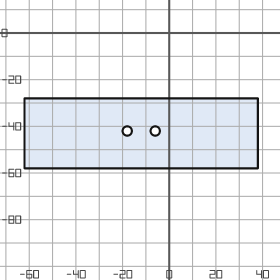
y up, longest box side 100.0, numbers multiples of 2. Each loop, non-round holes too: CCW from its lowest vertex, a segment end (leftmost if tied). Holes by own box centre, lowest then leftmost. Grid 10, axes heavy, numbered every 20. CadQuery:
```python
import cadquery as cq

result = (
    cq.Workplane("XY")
    .moveTo(-62.0, -58.0)
    .lineTo(38.0, -58.0)
    .lineTo(38.0, -28.0)
    .lineTo(-62.0, -28.0)
    .close()
    .moveTo(-18.0, -42.0)
    .circle(2.0)
    .moveTo(-6.0, -42.0)
    .circle(2.0)
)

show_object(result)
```